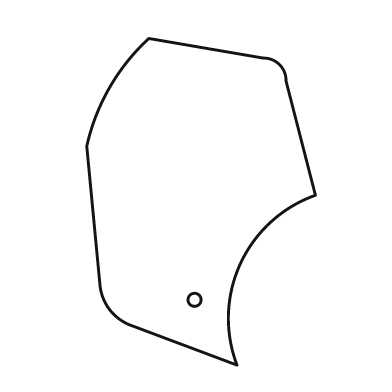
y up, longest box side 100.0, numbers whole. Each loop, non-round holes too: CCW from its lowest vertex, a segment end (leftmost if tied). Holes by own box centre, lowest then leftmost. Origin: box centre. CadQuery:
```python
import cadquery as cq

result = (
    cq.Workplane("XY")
    .moveTo(11.0, -50.0)
    .threePointArc((12.0, -19.0), (35.0, 2.0))
    .lineTo(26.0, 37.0)
    .threePointArc((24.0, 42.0), (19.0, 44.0))
    .lineTo(-16.0, 50.0)
    .threePointArc((-28.0, 35.0), (-35.0, 17.0))
    .lineTo(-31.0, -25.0)
    .threePointArc((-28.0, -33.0), (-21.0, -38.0))
    .close()
    .moveTo(-2.0, -30.0)
    .circle(2.0)
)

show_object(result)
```